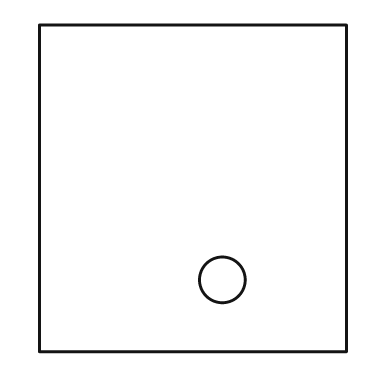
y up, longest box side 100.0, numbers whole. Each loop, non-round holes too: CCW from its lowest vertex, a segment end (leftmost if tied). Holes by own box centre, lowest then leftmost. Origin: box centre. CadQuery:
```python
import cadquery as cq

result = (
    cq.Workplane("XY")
    .moveTo(-47.0, -50.0)
    .lineTo(47.0, -50.0)
    .lineTo(47.0, 50.0)
    .lineTo(-47.0, 50.0)
    .close()
    .moveTo(9.0, -28.0)
    .circle(7.0)
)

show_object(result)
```